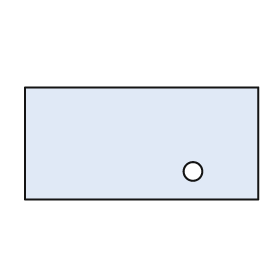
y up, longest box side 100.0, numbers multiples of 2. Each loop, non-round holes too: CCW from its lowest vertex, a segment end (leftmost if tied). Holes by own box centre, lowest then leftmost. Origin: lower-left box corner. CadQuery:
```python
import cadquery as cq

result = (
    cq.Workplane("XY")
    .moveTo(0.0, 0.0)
    .lineTo(100.0, 0.0)
    .lineTo(100.0, 48.0)
    .lineTo(0.0, 48.0)
    .close()
    .moveTo(72.0, 12.0)
    .circle(4.0)
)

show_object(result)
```